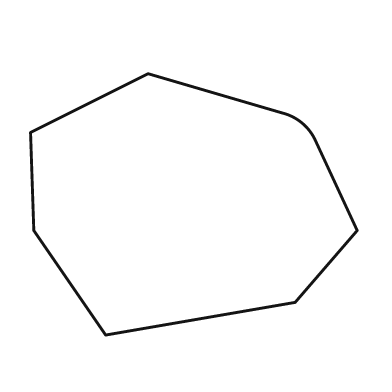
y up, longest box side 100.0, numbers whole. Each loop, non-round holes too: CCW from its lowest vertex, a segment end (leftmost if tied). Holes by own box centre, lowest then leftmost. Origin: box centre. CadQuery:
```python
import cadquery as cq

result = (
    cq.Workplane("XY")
    .moveTo(-27.0, -40.0)
    .lineTo(31.0, -30.0)
    .lineTo(50.0, -8.0)
    .lineTo(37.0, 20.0)
    .threePointArc((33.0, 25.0), (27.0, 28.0))
    .lineTo(-14.0, 40.0)
    .lineTo(-50.0, 22.0)
    .lineTo(-49.0, -8.0)
    .close()
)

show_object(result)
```